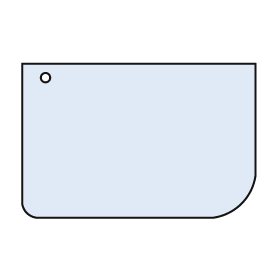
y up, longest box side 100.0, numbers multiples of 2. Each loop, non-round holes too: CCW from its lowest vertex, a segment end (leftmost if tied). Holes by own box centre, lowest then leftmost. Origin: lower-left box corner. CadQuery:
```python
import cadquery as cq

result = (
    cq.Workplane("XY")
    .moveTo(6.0, 0.0)
    .lineTo(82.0, 0.0)
    .threePointArc((94.0, 6.0), (100.0, 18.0))
    .lineTo(100.0, 66.0)
    .lineTo(0.0, 66.0)
    .lineTo(0.0, 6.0)
    .threePointArc((2.0, 2.0), (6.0, 0.0))
    .close()
    .moveTo(10.0, 60.0)
    .circle(2.0)
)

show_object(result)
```